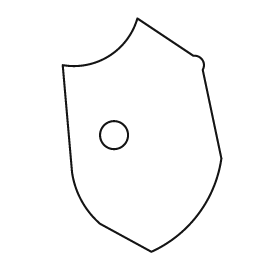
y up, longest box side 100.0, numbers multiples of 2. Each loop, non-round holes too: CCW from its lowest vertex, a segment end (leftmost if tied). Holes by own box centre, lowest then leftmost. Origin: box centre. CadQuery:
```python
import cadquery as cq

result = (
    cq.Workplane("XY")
    .moveTo(4.0, -50.0)
    .threePointArc((24.0, -34.0), (34.0, -10.0))
    .lineTo(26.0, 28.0)
    .threePointArc((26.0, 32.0), (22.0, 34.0))
    .lineTo(-2.0, 50.0)
    .threePointArc((-14.0, 34.0), (-34.0, 30.0))
    .lineTo(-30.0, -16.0)
    .threePointArc((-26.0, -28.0), (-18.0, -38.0))
    .close()
    .moveTo(-12.0, 0.0)
    .circle(6.0)
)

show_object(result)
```